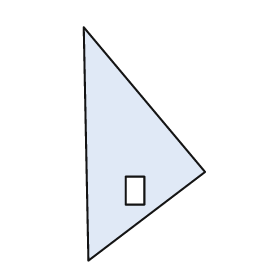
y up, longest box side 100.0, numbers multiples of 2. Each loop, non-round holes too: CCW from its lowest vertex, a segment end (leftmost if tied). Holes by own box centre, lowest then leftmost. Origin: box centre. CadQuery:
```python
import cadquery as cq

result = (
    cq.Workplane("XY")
    .moveTo(-24.0, -50.0)
    .lineTo(26.0, -12.0)
    .lineTo(-26.0, 50.0)
    .close()
    .moveTo(-8.0, -26.0)
    .lineTo(0.0, -26.0)
    .lineTo(0.0, -14.0)
    .lineTo(-8.0, -14.0)
    .close()
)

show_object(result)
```